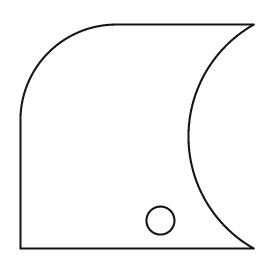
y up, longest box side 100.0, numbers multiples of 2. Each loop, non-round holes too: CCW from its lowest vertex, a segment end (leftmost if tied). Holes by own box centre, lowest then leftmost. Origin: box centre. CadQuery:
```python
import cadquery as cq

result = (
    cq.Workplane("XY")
    .moveTo(-50.0, -48.0)
    .lineTo(50.0, -48.0)
    .threePointArc((22.0, 0.0), (50.0, 48.0))
    .lineTo(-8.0, 48.0)
    .threePointArc((-38.0, 36.0), (-50.0, 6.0))
    .close()
    .moveTo(10.0, -36.0)
    .circle(6.0)
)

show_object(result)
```